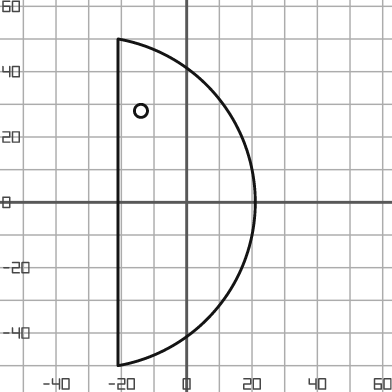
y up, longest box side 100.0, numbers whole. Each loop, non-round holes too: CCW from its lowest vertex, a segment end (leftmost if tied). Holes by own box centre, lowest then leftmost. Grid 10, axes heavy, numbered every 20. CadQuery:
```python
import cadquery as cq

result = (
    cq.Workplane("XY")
    .moveTo(-21.0, -50.0)
    .threePointArc((21.0, 0.0), (-21.0, 50.0))
    .close()
    .moveTo(-14.0, 28.0)
    .circle(2.0)
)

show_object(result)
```